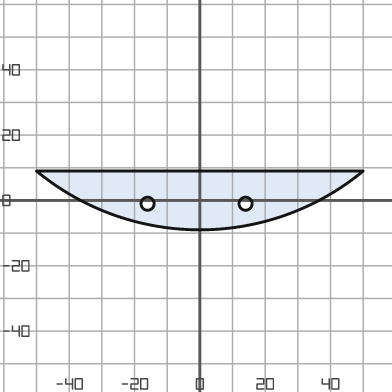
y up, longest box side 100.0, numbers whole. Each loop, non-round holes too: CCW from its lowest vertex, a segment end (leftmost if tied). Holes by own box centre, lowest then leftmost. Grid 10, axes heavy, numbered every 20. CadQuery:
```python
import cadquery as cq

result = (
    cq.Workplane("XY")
    .moveTo(-50.0, 9.0)
    .threePointArc((0.0, -9.0), (50.0, 9.0))
    .close()
    .moveTo(-16.0, -1.0)
    .circle(2.0)
    .moveTo(14.0, -1.0)
    .circle(2.0)
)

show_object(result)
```